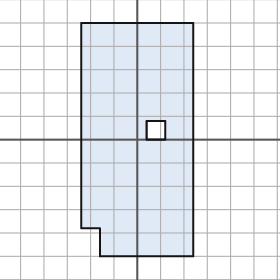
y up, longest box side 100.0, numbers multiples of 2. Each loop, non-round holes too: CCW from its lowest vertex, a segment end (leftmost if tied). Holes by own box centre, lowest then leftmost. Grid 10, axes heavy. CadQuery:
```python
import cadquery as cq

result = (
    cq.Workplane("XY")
    .moveTo(-16.0, -50.0)
    .lineTo(24.0, -50.0)
    .lineTo(24.0, 50.0)
    .lineTo(-24.0, 50.0)
    .lineTo(-24.0, -38.0)
    .lineTo(-16.0, -38.0)
    .close()
    .moveTo(4.0, 0.0)
    .lineTo(12.0, 0.0)
    .lineTo(12.0, 8.0)
    .lineTo(4.0, 8.0)
    .close()
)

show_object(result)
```